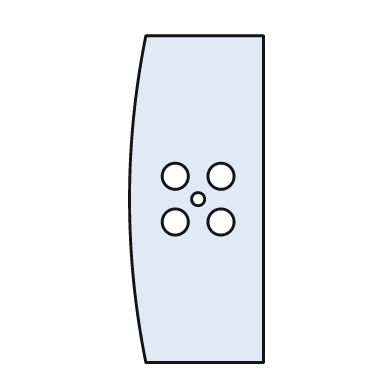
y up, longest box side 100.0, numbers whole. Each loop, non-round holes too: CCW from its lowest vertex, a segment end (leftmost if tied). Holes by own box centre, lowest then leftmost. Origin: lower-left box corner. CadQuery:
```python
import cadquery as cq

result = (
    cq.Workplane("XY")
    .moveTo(5.0, 0.0)
    .lineTo(41.0, 0.0)
    .lineTo(41.0, 100.0)
    .lineTo(5.0, 100.0)
    .threePointArc((0.0, 50.0), (5.0, 0.0))
    .close()
    .moveTo(14.0, 43.0)
    .circle(4.0)
    .moveTo(28.0, 43.0)
    .circle(4.0)
    .moveTo(21.0, 50.0)
    .circle(2.0)
    .moveTo(14.0, 57.0)
    .circle(4.0)
    .moveTo(28.0, 57.0)
    .circle(4.0)
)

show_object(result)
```